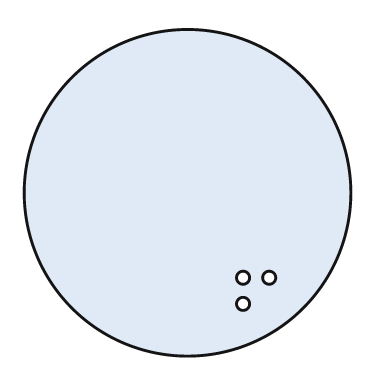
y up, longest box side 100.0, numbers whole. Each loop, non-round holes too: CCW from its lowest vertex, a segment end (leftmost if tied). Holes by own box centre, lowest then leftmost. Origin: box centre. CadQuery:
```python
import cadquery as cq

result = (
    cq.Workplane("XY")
    .moveTo(0.0, 0.0)
    .circle(50.0)
    .moveTo(17.0, -34.0)
    .circle(2.0)
    .moveTo(17.0, -26.0)
    .circle(2.0)
    .moveTo(25.0, -26.0)
    .circle(2.0)
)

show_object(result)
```